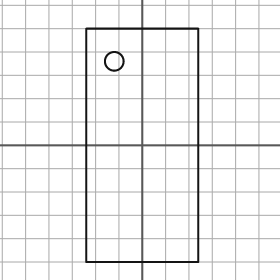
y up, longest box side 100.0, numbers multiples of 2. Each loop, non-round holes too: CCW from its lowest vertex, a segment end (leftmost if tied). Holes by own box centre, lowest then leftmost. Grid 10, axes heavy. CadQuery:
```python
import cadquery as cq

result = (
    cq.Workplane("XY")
    .moveTo(-24.0, -50.0)
    .lineTo(24.0, -50.0)
    .lineTo(24.0, 50.0)
    .lineTo(-24.0, 50.0)
    .close()
    .moveTo(-12.0, 36.0)
    .circle(4.0)
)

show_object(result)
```